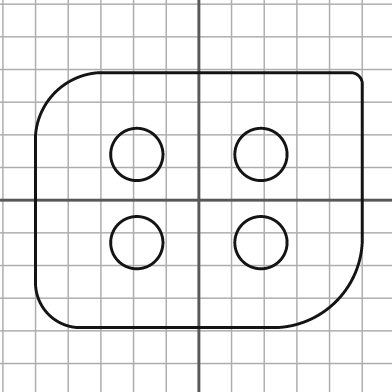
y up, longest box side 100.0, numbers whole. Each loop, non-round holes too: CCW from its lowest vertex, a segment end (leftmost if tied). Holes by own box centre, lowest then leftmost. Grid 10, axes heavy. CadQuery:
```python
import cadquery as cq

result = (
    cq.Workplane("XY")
    .moveTo(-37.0, -39.0)
    .lineTo(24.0, -39.0)
    .threePointArc((42.0, -31.0), (50.0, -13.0))
    .lineTo(50.0, 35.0)
    .threePointArc((49.0, 38.0), (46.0, 39.0))
    .lineTo(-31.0, 39.0)
    .threePointArc((-44.0, 33.0), (-50.0, 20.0))
    .lineTo(-50.0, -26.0)
    .threePointArc((-46.0, -35.0), (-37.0, -39.0))
    .close()
    .moveTo(-19.0, -13.0)
    .circle(8.0)
    .moveTo(19.0, -13.0)
    .circle(8.0)
    .moveTo(-19.0, 14.0)
    .circle(8.0)
    .moveTo(19.0, 14.0)
    .circle(8.0)
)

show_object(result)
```